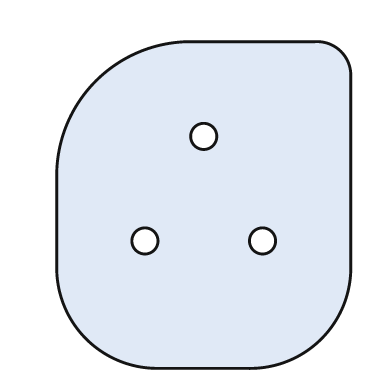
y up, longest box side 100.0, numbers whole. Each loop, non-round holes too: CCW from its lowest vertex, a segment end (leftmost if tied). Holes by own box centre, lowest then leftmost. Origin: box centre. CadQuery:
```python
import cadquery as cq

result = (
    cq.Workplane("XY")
    .moveTo(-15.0, -50.0)
    .lineTo(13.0, -50.0)
    .threePointArc((36.0, -41.0), (45.0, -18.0))
    .lineTo(45.0, 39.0)
    .threePointArc((42.0, 47.0), (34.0, 50.0))
    .lineTo(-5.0, 50.0)
    .threePointArc((-33.0, 38.0), (-45.0, 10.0))
    .lineTo(-45.0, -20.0)
    .threePointArc((-36.0, -41.0), (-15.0, -50.0))
    .close()
    .moveTo(-18.0, -11.0)
    .circle(4.0)
    .moveTo(18.0, -11.0)
    .circle(4.0)
    .moveTo(0.0, 21.0)
    .circle(4.0)
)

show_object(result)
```